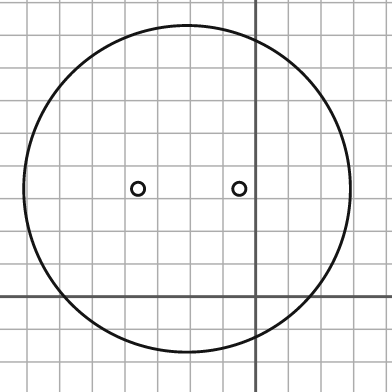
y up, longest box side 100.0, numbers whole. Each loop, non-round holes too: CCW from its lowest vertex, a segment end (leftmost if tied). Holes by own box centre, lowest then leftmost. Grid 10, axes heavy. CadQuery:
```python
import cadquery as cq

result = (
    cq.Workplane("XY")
    .moveTo(-21.0, 33.0)
    .circle(50.0)
    .moveTo(-36.0, 33.0)
    .circle(2.0)
    .moveTo(-5.0, 33.0)
    .circle(2.0)
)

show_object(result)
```